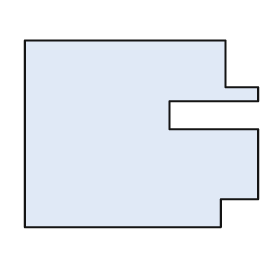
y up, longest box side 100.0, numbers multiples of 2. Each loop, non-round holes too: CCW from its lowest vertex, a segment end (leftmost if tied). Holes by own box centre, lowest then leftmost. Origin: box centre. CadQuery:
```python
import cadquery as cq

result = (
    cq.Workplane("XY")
    .moveTo(-50.0, -40.0)
    .lineTo(34.0, -40.0)
    .lineTo(34.0, -28.0)
    .lineTo(50.0, -28.0)
    .lineTo(50.0, 2.0)
    .lineTo(12.0, 2.0)
    .lineTo(12.0, 14.0)
    .lineTo(50.0, 14.0)
    .lineTo(50.0, 20.0)
    .lineTo(36.0, 20.0)
    .lineTo(36.0, 40.0)
    .lineTo(-50.0, 40.0)
    .close()
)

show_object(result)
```